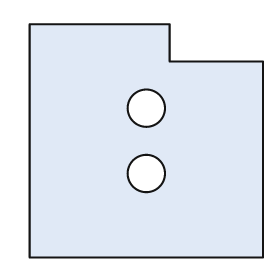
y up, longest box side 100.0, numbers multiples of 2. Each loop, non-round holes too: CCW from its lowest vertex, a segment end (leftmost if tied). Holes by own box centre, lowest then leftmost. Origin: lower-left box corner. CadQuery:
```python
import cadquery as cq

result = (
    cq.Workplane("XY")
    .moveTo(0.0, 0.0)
    .lineTo(100.0, 0.0)
    .lineTo(100.0, 84.0)
    .lineTo(60.0, 84.0)
    .lineTo(60.0, 100.0)
    .lineTo(0.0, 100.0)
    .close()
    .moveTo(50.0, 36.0)
    .circle(8.0)
    .moveTo(50.0, 64.0)
    .circle(8.0)
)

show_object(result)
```